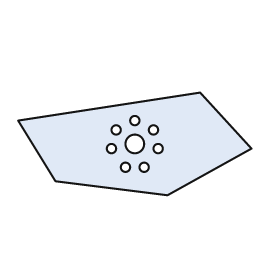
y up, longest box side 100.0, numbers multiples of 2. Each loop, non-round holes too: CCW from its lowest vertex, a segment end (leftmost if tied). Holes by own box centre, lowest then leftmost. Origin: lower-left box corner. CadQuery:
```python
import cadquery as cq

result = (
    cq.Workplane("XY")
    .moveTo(64.0, 0.0)
    .lineTo(100.0, 20.0)
    .lineTo(78.0, 44.0)
    .lineTo(0.0, 32.0)
    .lineTo(16.0, 6.0)
    .close()
    .moveTo(46.0, 12.0)
    .circle(2.0)
    .moveTo(54.0, 12.0)
    .circle(2.0)
    .moveTo(40.0, 20.0)
    .circle(2.0)
    .moveTo(60.0, 20.0)
    .circle(2.0)
    .moveTo(50.0, 22.0)
    .circle(4.0)
    .moveTo(42.0, 28.0)
    .circle(2.0)
    .moveTo(58.0, 28.0)
    .circle(2.0)
    .moveTo(50.0, 32.0)
    .circle(2.0)
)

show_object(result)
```